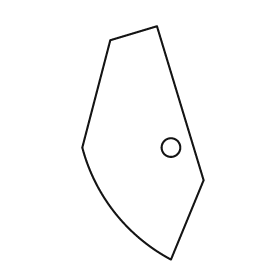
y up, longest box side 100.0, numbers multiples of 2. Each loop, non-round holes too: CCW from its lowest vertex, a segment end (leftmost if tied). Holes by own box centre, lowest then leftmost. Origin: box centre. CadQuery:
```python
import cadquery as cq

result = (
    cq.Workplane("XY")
    .moveTo(12.0, -50.0)
    .lineTo(26.0, -16.0)
    .lineTo(6.0, 50.0)
    .lineTo(-14.0, 44.0)
    .lineTo(-26.0, -2.0)
    .threePointArc((-12.0, -30.0), (12.0, -50.0))
    .close()
    .moveTo(12.0, -2.0)
    .circle(4.0)
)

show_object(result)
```